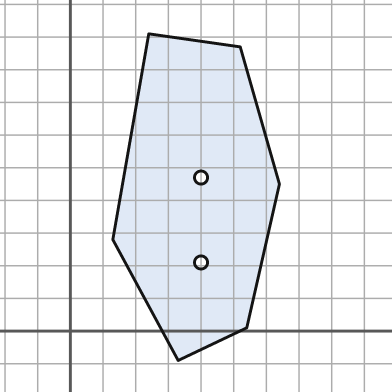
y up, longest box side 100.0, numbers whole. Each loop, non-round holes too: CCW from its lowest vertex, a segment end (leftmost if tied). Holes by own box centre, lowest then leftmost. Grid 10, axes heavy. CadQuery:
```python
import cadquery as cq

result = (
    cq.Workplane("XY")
    .moveTo(33.0, -9.0)
    .lineTo(54.0, 1.0)
    .lineTo(64.0, 45.0)
    .lineTo(52.0, 87.0)
    .lineTo(24.0, 91.0)
    .lineTo(13.0, 28.0)
    .close()
    .moveTo(40.0, 21.0)
    .circle(2.0)
    .moveTo(40.0, 47.0)
    .circle(2.0)
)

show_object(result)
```